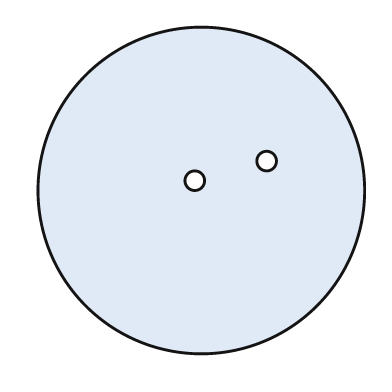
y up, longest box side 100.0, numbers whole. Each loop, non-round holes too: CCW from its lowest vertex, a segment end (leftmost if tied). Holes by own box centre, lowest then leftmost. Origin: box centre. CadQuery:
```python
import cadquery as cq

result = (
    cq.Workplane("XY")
    .moveTo(0.0, 0.0)
    .circle(50.0)
    .moveTo(-2.0, 3.0)
    .circle(3.0)
    .moveTo(20.0, 9.0)
    .circle(3.0)
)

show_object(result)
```